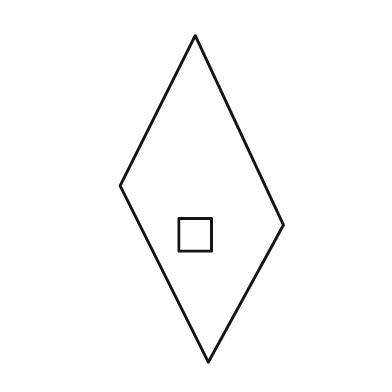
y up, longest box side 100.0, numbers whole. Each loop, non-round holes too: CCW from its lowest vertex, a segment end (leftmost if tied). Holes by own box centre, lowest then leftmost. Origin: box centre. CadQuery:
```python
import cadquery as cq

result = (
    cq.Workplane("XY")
    .moveTo(2.0, -50.0)
    .lineTo(25.0, -8.0)
    .lineTo(-2.0, 50.0)
    .lineTo(-25.0, 4.0)
    .close()
    .moveTo(-7.0, -16.0)
    .lineTo(3.0, -16.0)
    .lineTo(3.0, -6.0)
    .lineTo(-7.0, -6.0)
    .close()
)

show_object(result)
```